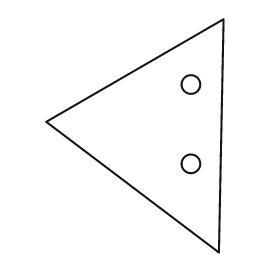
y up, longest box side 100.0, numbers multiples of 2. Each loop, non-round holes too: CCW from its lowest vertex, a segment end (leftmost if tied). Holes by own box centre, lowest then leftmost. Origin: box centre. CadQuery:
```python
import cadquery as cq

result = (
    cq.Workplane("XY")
    .moveTo(36.0, -50.0)
    .lineTo(38.0, 50.0)
    .lineTo(-38.0, 6.0)
    .close()
    .moveTo(24.0, -12.0)
    .circle(4.0)
    .moveTo(24.0, 22.0)
    .circle(4.0)
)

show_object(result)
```